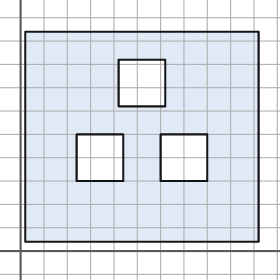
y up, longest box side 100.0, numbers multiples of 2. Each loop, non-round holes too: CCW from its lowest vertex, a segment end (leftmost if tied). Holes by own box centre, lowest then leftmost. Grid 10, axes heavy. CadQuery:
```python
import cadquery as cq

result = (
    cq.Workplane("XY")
    .moveTo(2.0, 4.0)
    .lineTo(102.0, 4.0)
    .lineTo(102.0, 94.0)
    .lineTo(2.0, 94.0)
    .close()
    .moveTo(24.0, 30.0)
    .lineTo(44.0, 30.0)
    .lineTo(44.0, 50.0)
    .lineTo(24.0, 50.0)
    .close()
    .moveTo(60.0, 30.0)
    .lineTo(80.0, 30.0)
    .lineTo(80.0, 50.0)
    .lineTo(60.0, 50.0)
    .close()
    .moveTo(42.0, 62.0)
    .lineTo(62.0, 62.0)
    .lineTo(62.0, 82.0)
    .lineTo(42.0, 82.0)
    .close()
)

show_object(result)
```